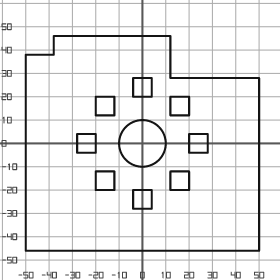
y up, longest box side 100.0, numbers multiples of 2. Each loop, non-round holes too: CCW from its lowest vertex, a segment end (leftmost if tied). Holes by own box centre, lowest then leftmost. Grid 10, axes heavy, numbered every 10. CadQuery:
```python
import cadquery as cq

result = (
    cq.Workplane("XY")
    .moveTo(-50.0, -46.0)
    .lineTo(50.0, -46.0)
    .lineTo(50.0, 28.0)
    .lineTo(12.0, 28.0)
    .lineTo(12.0, 46.0)
    .lineTo(-38.0, 46.0)
    .lineTo(-38.0, 38.0)
    .lineTo(-50.0, 38.0)
    .close()
    .moveTo(-4.0, -28.0)
    .lineTo(4.0, -28.0)
    .lineTo(4.0, -20.0)
    .lineTo(-4.0, -20.0)
    .close()
    .moveTo(-20.0, -20.0)
    .lineTo(-12.0, -20.0)
    .lineTo(-12.0, -12.0)
    .lineTo(-20.0, -12.0)
    .close()
    .moveTo(12.0, -20.0)
    .lineTo(20.0, -20.0)
    .lineTo(20.0, -12.0)
    .lineTo(12.0, -12.0)
    .close()
    .moveTo(-28.0, -4.0)
    .lineTo(-20.0, -4.0)
    .lineTo(-20.0, 4.0)
    .lineTo(-28.0, 4.0)
    .close()
    .moveTo(0.0, 0.0)
    .circle(10.0)
    .moveTo(20.0, -4.0)
    .lineTo(28.0, -4.0)
    .lineTo(28.0, 4.0)
    .lineTo(20.0, 4.0)
    .close()
    .moveTo(-20.0, 12.0)
    .lineTo(-12.0, 12.0)
    .lineTo(-12.0, 20.0)
    .lineTo(-20.0, 20.0)
    .close()
    .moveTo(12.0, 12.0)
    .lineTo(20.0, 12.0)
    .lineTo(20.0, 20.0)
    .lineTo(12.0, 20.0)
    .close()
    .moveTo(-4.0, 20.0)
    .lineTo(4.0, 20.0)
    .lineTo(4.0, 28.0)
    .lineTo(-4.0, 28.0)
    .close()
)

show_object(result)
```